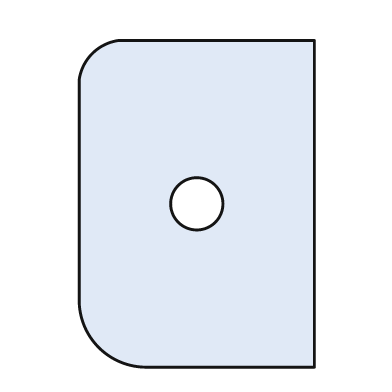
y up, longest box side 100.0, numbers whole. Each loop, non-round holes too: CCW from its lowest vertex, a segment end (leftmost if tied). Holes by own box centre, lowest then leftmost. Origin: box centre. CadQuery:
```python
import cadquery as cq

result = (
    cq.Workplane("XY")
    .moveTo(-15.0, -50.0)
    .lineTo(36.0, -50.0)
    .lineTo(36.0, 50.0)
    .lineTo(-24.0, 50.0)
    .threePointArc((-32.0, 46.0), (-36.0, 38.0))
    .lineTo(-36.0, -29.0)
    .threePointArc((-30.0, -44.0), (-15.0, -50.0))
    .close()
    .moveTo(0.0, 0.0)
    .circle(8.0)
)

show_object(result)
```